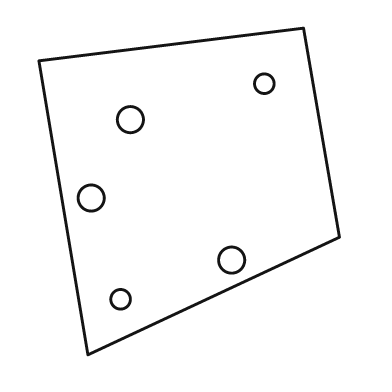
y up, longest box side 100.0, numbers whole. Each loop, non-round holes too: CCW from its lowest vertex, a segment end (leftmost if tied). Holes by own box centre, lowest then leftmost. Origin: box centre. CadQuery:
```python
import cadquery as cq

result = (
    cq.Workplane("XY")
    .moveTo(-31.0, -50.0)
    .lineTo(46.0, -14.0)
    .lineTo(35.0, 50.0)
    .lineTo(-46.0, 40.0)
    .close()
    .moveTo(-21.0, -33.0)
    .circle(3.0)
    .moveTo(13.0, -21.0)
    .circle(4.0)
    .moveTo(-30.0, -2.0)
    .circle(4.0)
    .moveTo(-18.0, 22.0)
    .circle(4.0)
    .moveTo(23.0, 33.0)
    .circle(3.0)
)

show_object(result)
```